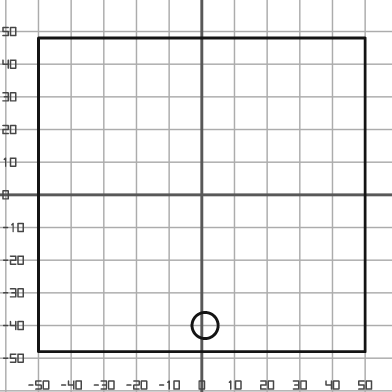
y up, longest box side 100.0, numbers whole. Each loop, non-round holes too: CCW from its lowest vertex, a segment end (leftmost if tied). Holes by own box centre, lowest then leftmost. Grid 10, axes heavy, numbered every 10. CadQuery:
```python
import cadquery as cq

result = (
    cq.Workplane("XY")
    .moveTo(-50.0, -48.0)
    .lineTo(50.0, -48.0)
    .lineTo(50.0, 48.0)
    .lineTo(-50.0, 48.0)
    .close()
    .moveTo(1.0, -40.0)
    .circle(4.0)
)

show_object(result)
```